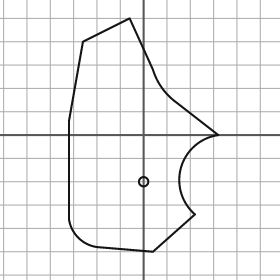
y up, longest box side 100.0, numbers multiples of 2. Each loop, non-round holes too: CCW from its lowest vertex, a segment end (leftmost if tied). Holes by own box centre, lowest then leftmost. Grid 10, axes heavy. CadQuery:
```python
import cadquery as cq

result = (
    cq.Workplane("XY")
    .moveTo(4.0, -50.0)
    .lineTo(22.0, -34.0)
    .threePointArc((16.0, -14.0), (32.0, 0.0))
    .lineTo(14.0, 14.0)
    .threePointArc((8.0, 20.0), (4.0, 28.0))
    .lineTo(-6.0, 50.0)
    .lineTo(-26.0, 40.0)
    .lineTo(-32.0, 6.0)
    .lineTo(-32.0, -36.0)
    .threePointArc((-28.0, -44.0), (-20.0, -48.0))
    .close()
    .moveTo(0.0, -20.0)
    .circle(2.0)
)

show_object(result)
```